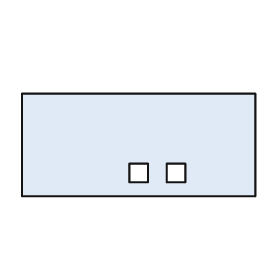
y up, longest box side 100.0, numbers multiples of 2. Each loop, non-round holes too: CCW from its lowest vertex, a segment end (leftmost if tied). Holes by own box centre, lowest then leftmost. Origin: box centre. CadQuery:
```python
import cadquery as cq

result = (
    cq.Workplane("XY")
    .moveTo(-50.0, -22.0)
    .lineTo(50.0, -22.0)
    .lineTo(50.0, 22.0)
    .lineTo(-50.0, 22.0)
    .close()
    .moveTo(-4.0, -16.0)
    .lineTo(4.0, -16.0)
    .lineTo(4.0, -8.0)
    .lineTo(-4.0, -8.0)
    .close()
    .moveTo(12.0, -16.0)
    .lineTo(20.0, -16.0)
    .lineTo(20.0, -8.0)
    .lineTo(12.0, -8.0)
    .close()
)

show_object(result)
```